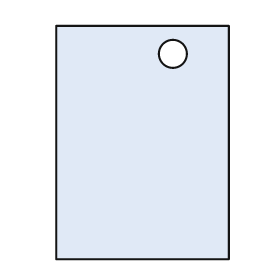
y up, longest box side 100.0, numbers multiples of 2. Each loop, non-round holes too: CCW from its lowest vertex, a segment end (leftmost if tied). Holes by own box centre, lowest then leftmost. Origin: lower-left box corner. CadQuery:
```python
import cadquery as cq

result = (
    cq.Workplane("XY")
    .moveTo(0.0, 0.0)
    .lineTo(74.0, 0.0)
    .lineTo(74.0, 100.0)
    .lineTo(0.0, 100.0)
    .close()
    .moveTo(50.0, 88.0)
    .circle(6.0)
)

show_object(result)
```